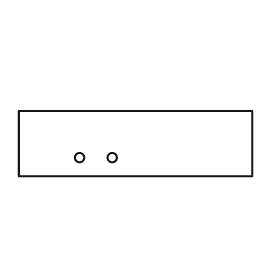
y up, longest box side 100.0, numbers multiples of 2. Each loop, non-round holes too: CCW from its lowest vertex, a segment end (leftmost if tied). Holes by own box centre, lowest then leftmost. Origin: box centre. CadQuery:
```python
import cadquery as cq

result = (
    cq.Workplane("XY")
    .moveTo(-50.0, -14.0)
    .lineTo(50.0, -14.0)
    .lineTo(50.0, 14.0)
    .lineTo(-50.0, 14.0)
    .close()
    .moveTo(-24.0, -6.0)
    .circle(2.0)
    .moveTo(-10.0, -6.0)
    .circle(2.0)
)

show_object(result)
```